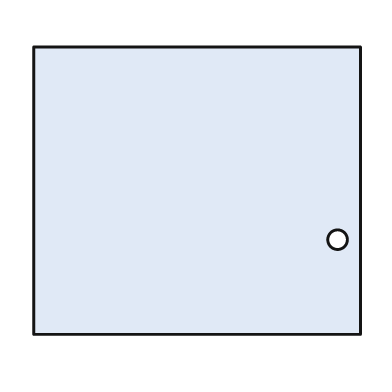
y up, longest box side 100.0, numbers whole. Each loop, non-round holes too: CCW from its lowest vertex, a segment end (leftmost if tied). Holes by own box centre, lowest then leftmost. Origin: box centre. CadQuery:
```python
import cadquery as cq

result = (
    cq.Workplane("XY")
    .moveTo(-50.0, -44.0)
    .lineTo(50.0, -44.0)
    .lineTo(50.0, 44.0)
    .lineTo(-50.0, 44.0)
    .close()
    .moveTo(43.0, -15.0)
    .circle(3.0)
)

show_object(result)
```